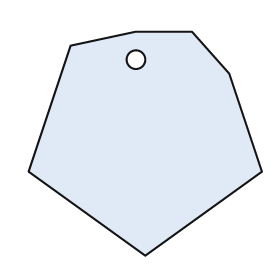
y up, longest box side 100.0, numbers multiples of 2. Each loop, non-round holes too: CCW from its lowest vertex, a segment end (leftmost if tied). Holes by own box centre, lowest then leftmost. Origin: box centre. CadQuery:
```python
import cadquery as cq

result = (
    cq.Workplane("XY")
    .moveTo(0.0, -48.0)
    .lineTo(50.0, -12.0)
    .lineTo(36.0, 30.0)
    .lineTo(20.0, 48.0)
    .lineTo(-4.0, 48.0)
    .lineTo(-32.0, 42.0)
    .lineTo(-50.0, -12.0)
    .close()
    .moveTo(-4.0, 36.0)
    .circle(4.0)
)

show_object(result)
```